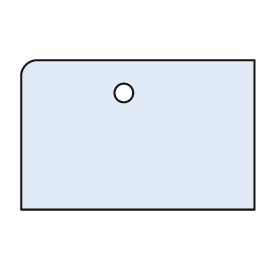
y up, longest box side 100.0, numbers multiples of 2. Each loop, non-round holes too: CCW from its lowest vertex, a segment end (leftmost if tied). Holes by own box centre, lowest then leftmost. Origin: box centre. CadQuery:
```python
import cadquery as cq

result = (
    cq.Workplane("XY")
    .moveTo(-50.0, -32.0)
    .lineTo(50.0, -32.0)
    .lineTo(50.0, 32.0)
    .lineTo(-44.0, 32.0)
    .threePointArc((-48.0, 30.0), (-50.0, 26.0))
    .close()
    .moveTo(-6.0, 18.0)
    .circle(4.0)
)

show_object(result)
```